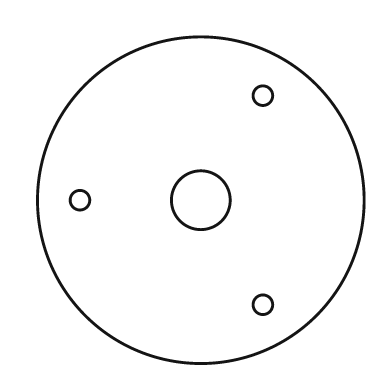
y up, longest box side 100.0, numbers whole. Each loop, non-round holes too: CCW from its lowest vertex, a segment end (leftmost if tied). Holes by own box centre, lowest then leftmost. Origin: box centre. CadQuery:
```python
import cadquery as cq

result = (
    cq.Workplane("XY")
    .moveTo(0.0, 0.0)
    .circle(50.0)
    .moveTo(19.0, -32.0)
    .circle(3.0)
    .moveTo(-37.0, 0.0)
    .circle(3.0)
    .moveTo(0.0, 0.0)
    .circle(9.0)
    .moveTo(19.0, 32.0)
    .circle(3.0)
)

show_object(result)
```